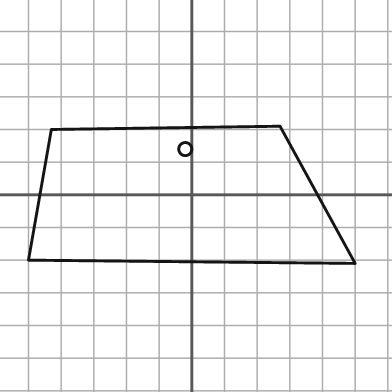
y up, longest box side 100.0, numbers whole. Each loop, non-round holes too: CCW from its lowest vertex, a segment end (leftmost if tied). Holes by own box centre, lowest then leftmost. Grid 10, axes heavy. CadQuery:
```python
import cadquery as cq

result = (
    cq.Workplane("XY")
    .moveTo(50.0, -21.0)
    .lineTo(27.0, 21.0)
    .lineTo(-43.0, 20.0)
    .lineTo(-50.0, -20.0)
    .close()
    .moveTo(-2.0, 14.0)
    .circle(2.0)
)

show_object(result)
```